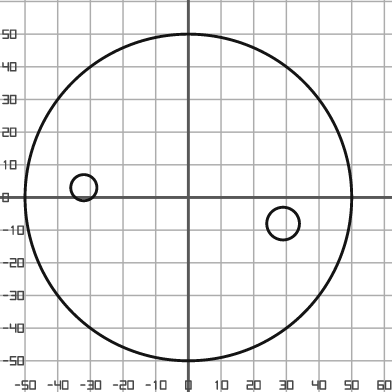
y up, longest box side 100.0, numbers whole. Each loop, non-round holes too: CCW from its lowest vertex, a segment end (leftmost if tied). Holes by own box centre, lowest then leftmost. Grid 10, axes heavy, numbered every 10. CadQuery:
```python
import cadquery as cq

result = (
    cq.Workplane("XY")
    .moveTo(0.0, 0.0)
    .circle(50.0)
    .moveTo(29.0, -8.0)
    .circle(5.0)
    .moveTo(-32.0, 3.0)
    .circle(4.0)
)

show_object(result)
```